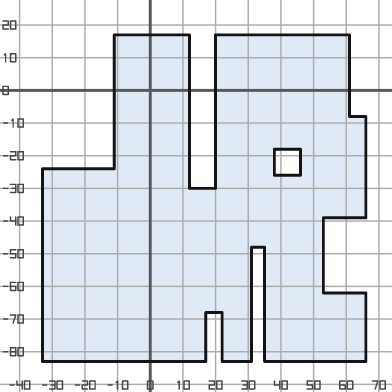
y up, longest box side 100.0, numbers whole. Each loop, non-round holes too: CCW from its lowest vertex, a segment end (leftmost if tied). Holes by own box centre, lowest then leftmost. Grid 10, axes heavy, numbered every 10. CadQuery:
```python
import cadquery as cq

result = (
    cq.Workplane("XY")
    .moveTo(-33.0, -83.0)
    .lineTo(17.0, -83.0)
    .lineTo(17.0, -68.0)
    .lineTo(22.0, -68.0)
    .lineTo(22.0, -83.0)
    .lineTo(31.0, -83.0)
    .lineTo(31.0, -48.0)
    .lineTo(35.0, -48.0)
    .lineTo(35.0, -83.0)
    .lineTo(66.0, -83.0)
    .lineTo(66.0, -62.0)
    .lineTo(53.0, -62.0)
    .lineTo(53.0, -39.0)
    .lineTo(66.0, -39.0)
    .lineTo(66.0, -8.0)
    .lineTo(61.0, -8.0)
    .lineTo(61.0, 17.0)
    .lineTo(20.0, 17.0)
    .lineTo(20.0, -30.0)
    .lineTo(12.0, -30.0)
    .lineTo(12.0, 17.0)
    .lineTo(-11.0, 17.0)
    .lineTo(-11.0, -24.0)
    .lineTo(-33.0, -24.0)
    .close()
    .moveTo(38.0, -26.0)
    .lineTo(46.0, -26.0)
    .lineTo(46.0, -18.0)
    .lineTo(38.0, -18.0)
    .close()
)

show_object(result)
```